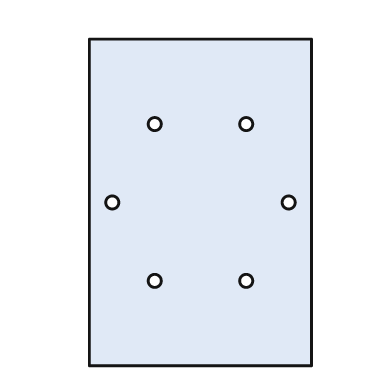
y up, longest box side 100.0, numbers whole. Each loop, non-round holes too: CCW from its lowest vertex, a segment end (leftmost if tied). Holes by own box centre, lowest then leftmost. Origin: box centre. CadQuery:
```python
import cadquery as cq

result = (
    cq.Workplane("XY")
    .moveTo(-34.0, -50.0)
    .lineTo(34.0, -50.0)
    .lineTo(34.0, 50.0)
    .lineTo(-34.0, 50.0)
    .close()
    .moveTo(-14.0, -24.0)
    .circle(2.0)
    .moveTo(14.0, -24.0)
    .circle(2.0)
    .moveTo(-27.0, 0.0)
    .circle(2.0)
    .moveTo(27.0, 0.0)
    .circle(2.0)
    .moveTo(-14.0, 24.0)
    .circle(2.0)
    .moveTo(14.0, 24.0)
    .circle(2.0)
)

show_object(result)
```